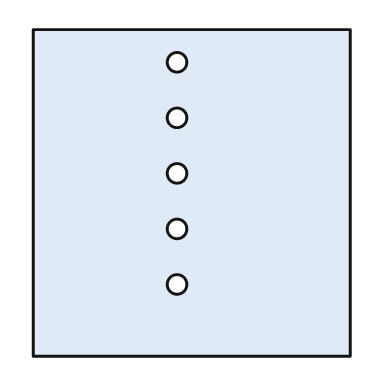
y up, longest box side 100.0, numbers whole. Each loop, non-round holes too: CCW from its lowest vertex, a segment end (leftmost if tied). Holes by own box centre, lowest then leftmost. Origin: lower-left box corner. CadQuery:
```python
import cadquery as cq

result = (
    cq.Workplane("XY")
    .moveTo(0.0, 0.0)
    .lineTo(97.0, 0.0)
    .lineTo(97.0, 100.0)
    .lineTo(0.0, 100.0)
    .close()
    .moveTo(44.0, 22.0)
    .circle(3.0)
    .moveTo(44.0, 39.0)
    .circle(3.0)
    .moveTo(44.0, 56.0)
    .circle(3.0)
    .moveTo(44.0, 73.0)
    .circle(3.0)
    .moveTo(44.0, 90.0)
    .circle(3.0)
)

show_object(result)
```